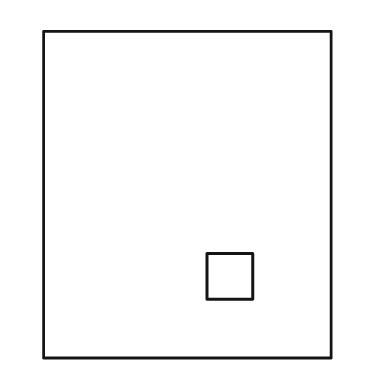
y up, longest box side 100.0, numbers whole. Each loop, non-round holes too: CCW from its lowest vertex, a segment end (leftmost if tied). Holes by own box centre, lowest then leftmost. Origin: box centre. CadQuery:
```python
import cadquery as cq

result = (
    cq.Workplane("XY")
    .moveTo(-44.0, -50.0)
    .lineTo(44.0, -50.0)
    .lineTo(44.0, 50.0)
    .lineTo(-44.0, 50.0)
    .close()
    .moveTo(6.0, -32.0)
    .lineTo(20.0, -32.0)
    .lineTo(20.0, -18.0)
    .lineTo(6.0, -18.0)
    .close()
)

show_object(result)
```